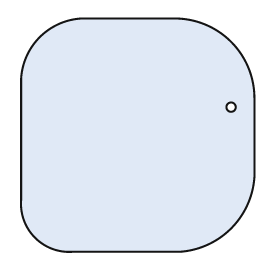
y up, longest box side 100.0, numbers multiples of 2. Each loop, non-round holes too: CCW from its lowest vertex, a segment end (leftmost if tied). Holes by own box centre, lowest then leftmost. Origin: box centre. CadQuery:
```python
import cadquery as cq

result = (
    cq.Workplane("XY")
    .moveTo(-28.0, -50.0)
    .lineTo(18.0, -50.0)
    .threePointArc((40.0, -40.0), (50.0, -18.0))
    .lineTo(50.0, 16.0)
    .threePointArc((40.0, 40.0), (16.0, 50.0))
    .lineTo(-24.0, 50.0)
    .threePointArc((-42.0, 42.0), (-50.0, 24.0))
    .lineTo(-50.0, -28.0)
    .threePointArc((-44.0, -44.0), (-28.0, -50.0))
    .close()
    .moveTo(40.0, 12.0)
    .circle(2.0)
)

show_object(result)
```